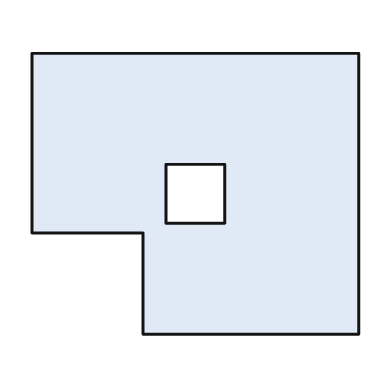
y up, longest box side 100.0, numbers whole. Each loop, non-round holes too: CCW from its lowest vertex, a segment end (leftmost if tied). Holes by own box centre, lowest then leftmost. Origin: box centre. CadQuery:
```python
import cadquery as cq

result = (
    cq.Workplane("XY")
    .moveTo(-16.0, -43.0)
    .lineTo(50.0, -43.0)
    .lineTo(50.0, 43.0)
    .lineTo(-50.0, 43.0)
    .lineTo(-50.0, -12.0)
    .lineTo(-16.0, -12.0)
    .close()
    .moveTo(-9.0, -9.0)
    .lineTo(9.0, -9.0)
    .lineTo(9.0, 9.0)
    .lineTo(-9.0, 9.0)
    .close()
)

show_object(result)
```